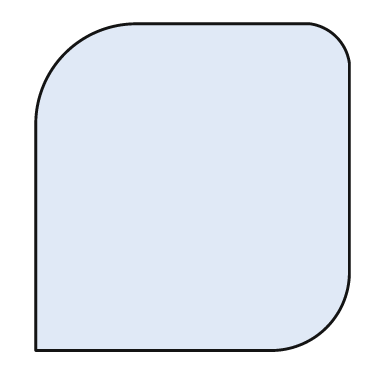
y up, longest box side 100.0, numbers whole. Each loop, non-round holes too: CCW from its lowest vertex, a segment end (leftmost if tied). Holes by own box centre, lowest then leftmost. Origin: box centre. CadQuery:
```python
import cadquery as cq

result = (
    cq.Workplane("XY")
    .moveTo(-48.0, -50.0)
    .lineTo(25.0, -50.0)
    .threePointArc((41.0, -43.0), (48.0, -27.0))
    .lineTo(48.0, 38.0)
    .threePointArc((44.0, 46.0), (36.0, 50.0))
    .lineTo(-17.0, 50.0)
    .threePointArc((-39.0, 41.0), (-48.0, 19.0))
    .close()
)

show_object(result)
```